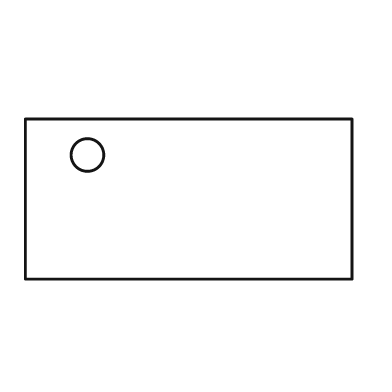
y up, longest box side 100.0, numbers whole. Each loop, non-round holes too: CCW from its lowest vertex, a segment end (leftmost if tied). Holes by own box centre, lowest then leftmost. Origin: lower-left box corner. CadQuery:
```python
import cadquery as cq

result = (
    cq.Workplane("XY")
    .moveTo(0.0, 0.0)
    .lineTo(100.0, 0.0)
    .lineTo(100.0, 49.0)
    .lineTo(0.0, 49.0)
    .close()
    .moveTo(19.0, 38.0)
    .circle(5.0)
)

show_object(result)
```